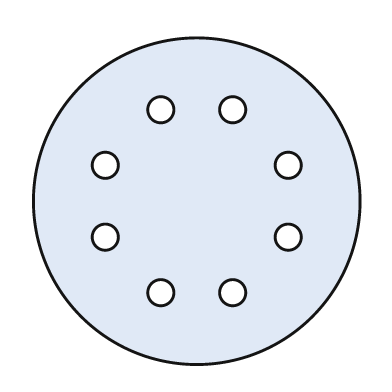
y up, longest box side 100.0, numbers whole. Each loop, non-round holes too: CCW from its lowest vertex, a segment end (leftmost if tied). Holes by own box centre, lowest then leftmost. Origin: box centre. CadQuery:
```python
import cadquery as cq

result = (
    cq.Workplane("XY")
    .moveTo(0.0, 0.0)
    .circle(50.0)
    .moveTo(-11.0, -28.0)
    .circle(4.0)
    .moveTo(11.0, -28.0)
    .circle(4.0)
    .moveTo(-28.0, -11.0)
    .circle(4.0)
    .moveTo(28.0, -11.0)
    .circle(4.0)
    .moveTo(-28.0, 11.0)
    .circle(4.0)
    .moveTo(28.0, 11.0)
    .circle(4.0)
    .moveTo(-11.0, 28.0)
    .circle(4.0)
    .moveTo(11.0, 28.0)
    .circle(4.0)
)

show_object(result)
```